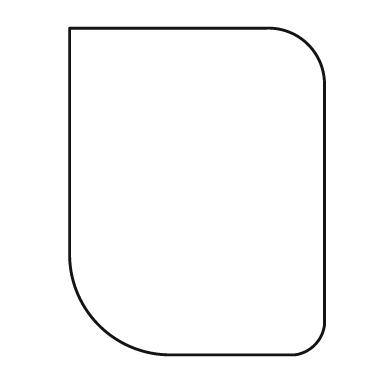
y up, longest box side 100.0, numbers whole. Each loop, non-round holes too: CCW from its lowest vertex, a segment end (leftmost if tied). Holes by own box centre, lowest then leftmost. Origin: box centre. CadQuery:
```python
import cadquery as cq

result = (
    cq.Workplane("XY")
    .moveTo(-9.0, -50.0)
    .lineTo(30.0, -50.0)
    .threePointArc((36.0, -47.0), (39.0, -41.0))
    .lineTo(39.0, 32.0)
    .threePointArc((34.0, 45.0), (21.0, 50.0))
    .lineTo(-39.0, 50.0)
    .lineTo(-39.0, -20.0)
    .threePointArc((-30.0, -41.0), (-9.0, -50.0))
    .close()
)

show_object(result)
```